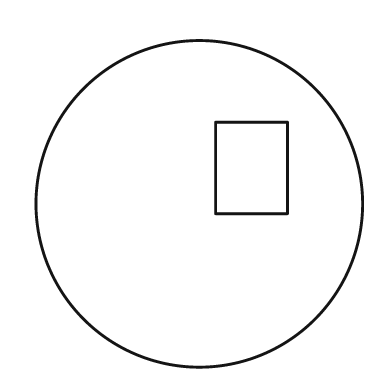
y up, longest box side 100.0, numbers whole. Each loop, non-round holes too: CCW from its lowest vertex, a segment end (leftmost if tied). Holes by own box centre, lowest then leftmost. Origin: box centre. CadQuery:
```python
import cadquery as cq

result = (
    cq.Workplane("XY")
    .moveTo(0.0, 0.0)
    .circle(50.0)
    .moveTo(5.0, -3.0)
    .lineTo(27.0, -3.0)
    .lineTo(27.0, 25.0)
    .lineTo(5.0, 25.0)
    .close()
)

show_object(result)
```